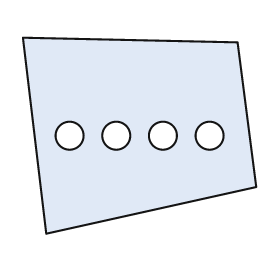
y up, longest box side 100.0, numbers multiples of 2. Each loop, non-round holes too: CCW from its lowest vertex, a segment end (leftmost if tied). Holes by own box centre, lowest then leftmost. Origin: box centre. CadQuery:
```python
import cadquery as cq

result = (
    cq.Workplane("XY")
    .moveTo(-40.0, -42.0)
    .lineTo(50.0, -22.0)
    .lineTo(42.0, 40.0)
    .lineTo(-50.0, 42.0)
    .close()
    .moveTo(-30.0, 0.0)
    .circle(6.0)
    .moveTo(-10.0, 0.0)
    .circle(6.0)
    .moveTo(10.0, 0.0)
    .circle(6.0)
    .moveTo(30.0, 0.0)
    .circle(6.0)
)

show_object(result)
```